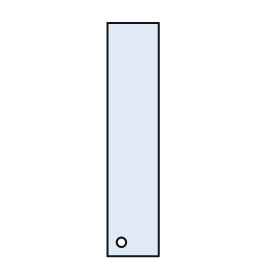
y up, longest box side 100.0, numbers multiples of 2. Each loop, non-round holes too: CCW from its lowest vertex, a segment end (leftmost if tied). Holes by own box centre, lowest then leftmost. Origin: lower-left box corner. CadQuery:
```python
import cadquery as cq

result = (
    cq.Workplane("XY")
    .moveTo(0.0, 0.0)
    .lineTo(22.0, 0.0)
    .lineTo(22.0, 100.0)
    .lineTo(0.0, 100.0)
    .close()
    .moveTo(6.0, 6.0)
    .circle(2.0)
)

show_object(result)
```